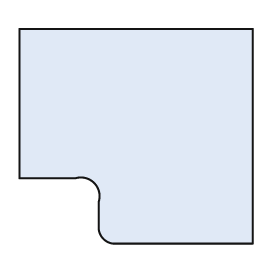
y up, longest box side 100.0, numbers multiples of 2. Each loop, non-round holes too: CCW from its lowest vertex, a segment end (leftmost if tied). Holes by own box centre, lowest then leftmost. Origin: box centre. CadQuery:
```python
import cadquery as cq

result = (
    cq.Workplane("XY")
    .moveTo(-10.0, -46.0)
    .lineTo(50.0, -46.0)
    .lineTo(50.0, 46.0)
    .lineTo(-50.0, 46.0)
    .lineTo(-50.0, -18.0)
    .lineTo(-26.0, -18.0)
    .threePointArc((-18.0, -20.0), (-16.0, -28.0))
    .lineTo(-16.0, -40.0)
    .threePointArc((-14.0, -44.0), (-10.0, -46.0))
    .close()
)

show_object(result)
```